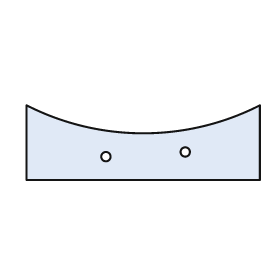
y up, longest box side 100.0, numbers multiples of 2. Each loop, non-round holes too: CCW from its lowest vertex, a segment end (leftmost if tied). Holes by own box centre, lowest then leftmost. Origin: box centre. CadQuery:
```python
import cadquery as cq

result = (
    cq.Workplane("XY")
    .moveTo(-50.0, -16.0)
    .lineTo(50.0, -16.0)
    .lineTo(50.0, 16.0)
    .threePointArc((0.0, 4.0), (-50.0, 16.0))
    .close()
    .moveTo(-16.0, -6.0)
    .circle(2.0)
    .moveTo(18.0, -4.0)
    .circle(2.0)
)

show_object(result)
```